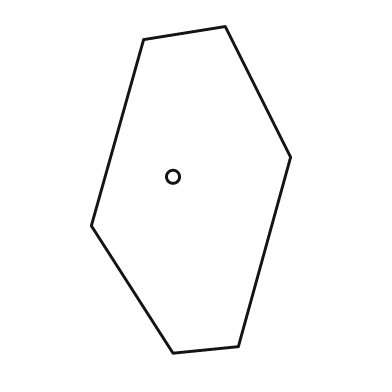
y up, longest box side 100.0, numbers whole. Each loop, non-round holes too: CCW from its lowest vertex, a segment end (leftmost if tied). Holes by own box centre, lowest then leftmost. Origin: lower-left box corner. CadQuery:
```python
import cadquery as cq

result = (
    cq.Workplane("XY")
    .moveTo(25.0, 0.0)
    .lineTo(45.0, 2.0)
    .lineTo(61.0, 60.0)
    .lineTo(41.0, 100.0)
    .lineTo(16.0, 96.0)
    .lineTo(0.0, 39.0)
    .close()
    .moveTo(25.0, 54.0)
    .circle(2.0)
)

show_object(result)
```